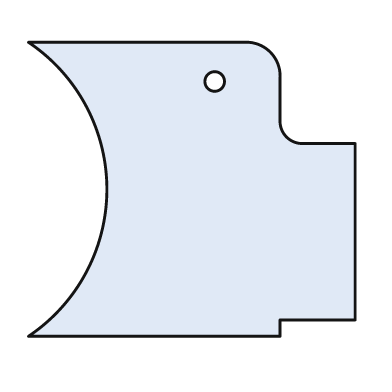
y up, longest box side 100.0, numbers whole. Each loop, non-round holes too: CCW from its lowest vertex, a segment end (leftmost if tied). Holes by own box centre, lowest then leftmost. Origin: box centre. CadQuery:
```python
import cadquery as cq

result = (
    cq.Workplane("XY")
    .moveTo(-50.0, -45.0)
    .lineTo(27.0, -45.0)
    .lineTo(27.0, -40.0)
    .lineTo(50.0, -40.0)
    .lineTo(50.0, 14.0)
    .lineTo(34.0, 14.0)
    .threePointArc((29.0, 16.0), (27.0, 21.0))
    .lineTo(27.0, 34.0)
    .threePointArc((24.0, 42.0), (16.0, 45.0))
    .lineTo(-50.0, 45.0)
    .threePointArc((-26.0, 0.0), (-50.0, -45.0))
    .close()
    .moveTo(7.0, 33.0)
    .circle(3.0)
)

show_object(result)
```